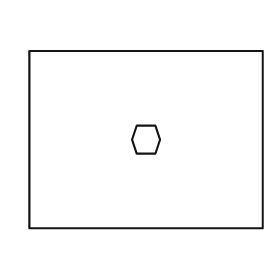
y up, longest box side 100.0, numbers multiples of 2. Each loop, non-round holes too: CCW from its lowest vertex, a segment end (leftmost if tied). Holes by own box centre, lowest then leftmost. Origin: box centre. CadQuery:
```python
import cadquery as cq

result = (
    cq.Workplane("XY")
    .moveTo(-50.0, -38.0)
    .lineTo(50.0, -38.0)
    .lineTo(50.0, 38.0)
    .lineTo(-50.0, 38.0)
    .close()
    .moveTo(-4.0, -6.0)
    .lineTo(4.0, -6.0)
    .lineTo(6.0, 0.0)
    .lineTo(4.0, 6.0)
    .lineTo(-4.0, 6.0)
    .lineTo(-6.0, 0.0)
    .close()
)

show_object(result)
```